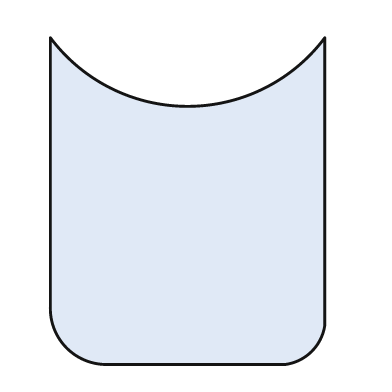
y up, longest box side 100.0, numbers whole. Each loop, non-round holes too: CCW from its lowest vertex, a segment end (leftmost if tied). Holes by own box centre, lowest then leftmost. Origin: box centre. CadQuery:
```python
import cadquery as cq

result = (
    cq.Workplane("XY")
    .moveTo(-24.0, -50.0)
    .lineTo(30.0, -50.0)
    .threePointArc((38.0, -46.0), (42.0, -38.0))
    .lineTo(42.0, 50.0)
    .threePointArc((0.0, 29.0), (-42.0, 50.0))
    .lineTo(-42.0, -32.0)
    .threePointArc((-37.0, -45.0), (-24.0, -50.0))
    .close()
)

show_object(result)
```